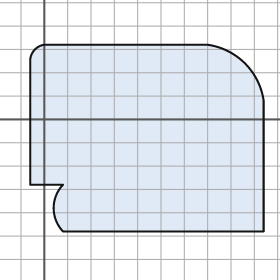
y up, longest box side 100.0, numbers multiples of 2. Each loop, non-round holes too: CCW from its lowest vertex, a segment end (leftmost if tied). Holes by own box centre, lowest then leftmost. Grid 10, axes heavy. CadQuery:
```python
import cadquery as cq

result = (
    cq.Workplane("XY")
    .moveTo(8.0, -48.0)
    .lineTo(94.0, -48.0)
    .lineTo(94.0, 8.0)
    .threePointArc((86.0, 24.0), (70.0, 32.0))
    .lineTo(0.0, 32.0)
    .threePointArc((-4.0, 30.0), (-6.0, 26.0))
    .lineTo(-6.0, -28.0)
    .lineTo(8.0, -28.0)
    .threePointArc((4.0, -38.0), (8.0, -48.0))
    .close()
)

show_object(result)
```